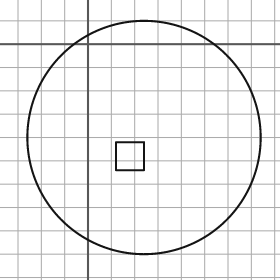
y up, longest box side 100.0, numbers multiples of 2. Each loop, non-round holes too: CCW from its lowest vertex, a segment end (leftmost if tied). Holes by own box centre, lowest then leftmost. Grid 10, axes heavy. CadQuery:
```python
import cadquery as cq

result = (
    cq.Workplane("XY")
    .moveTo(24.0, -40.0)
    .circle(50.0)
    .moveTo(12.0, -54.0)
    .lineTo(24.0, -54.0)
    .lineTo(24.0, -42.0)
    .lineTo(12.0, -42.0)
    .close()
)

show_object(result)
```